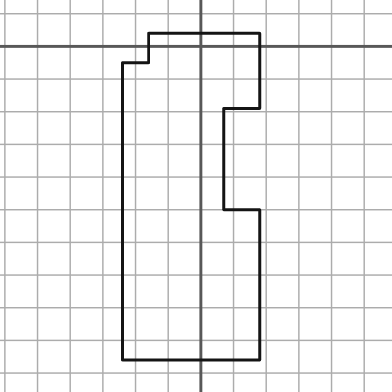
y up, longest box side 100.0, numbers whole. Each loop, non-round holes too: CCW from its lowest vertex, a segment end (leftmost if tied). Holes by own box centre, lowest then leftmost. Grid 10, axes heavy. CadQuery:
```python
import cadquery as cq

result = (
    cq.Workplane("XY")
    .moveTo(-24.0, -96.0)
    .lineTo(18.0, -96.0)
    .lineTo(18.0, -50.0)
    .lineTo(7.0, -50.0)
    .lineTo(7.0, -19.0)
    .lineTo(18.0, -19.0)
    .lineTo(18.0, 4.0)
    .lineTo(-16.0, 4.0)
    .lineTo(-16.0, -5.0)
    .lineTo(-24.0, -5.0)
    .close()
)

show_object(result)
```